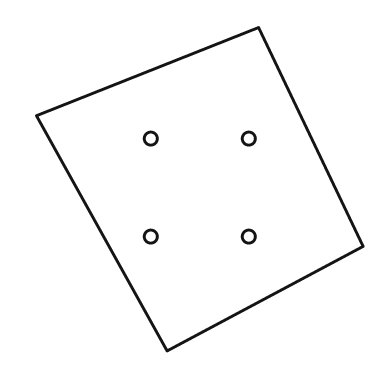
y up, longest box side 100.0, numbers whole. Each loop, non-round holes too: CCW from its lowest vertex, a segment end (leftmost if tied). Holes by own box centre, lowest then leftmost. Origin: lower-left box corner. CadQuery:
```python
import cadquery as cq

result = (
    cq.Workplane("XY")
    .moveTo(40.0, 0.0)
    .lineTo(100.0, 32.0)
    .lineTo(68.0, 99.0)
    .lineTo(0.0, 72.0)
    .close()
    .moveTo(35.0, 35.0)
    .circle(2.0)
    .moveTo(65.0, 35.0)
    .circle(2.0)
    .moveTo(35.0, 65.0)
    .circle(2.0)
    .moveTo(65.0, 65.0)
    .circle(2.0)
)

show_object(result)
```